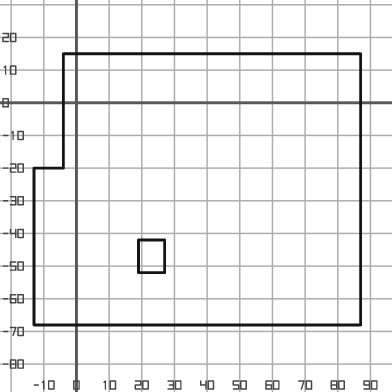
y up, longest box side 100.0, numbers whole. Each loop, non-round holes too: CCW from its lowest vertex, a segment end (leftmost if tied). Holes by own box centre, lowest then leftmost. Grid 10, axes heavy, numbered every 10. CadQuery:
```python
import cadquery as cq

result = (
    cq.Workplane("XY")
    .moveTo(-13.0, -68.0)
    .lineTo(87.0, -68.0)
    .lineTo(87.0, 15.0)
    .lineTo(-4.0, 15.0)
    .lineTo(-4.0, -20.0)
    .lineTo(-13.0, -20.0)
    .close()
    .moveTo(19.0, -52.0)
    .lineTo(27.0, -52.0)
    .lineTo(27.0, -42.0)
    .lineTo(19.0, -42.0)
    .close()
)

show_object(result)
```